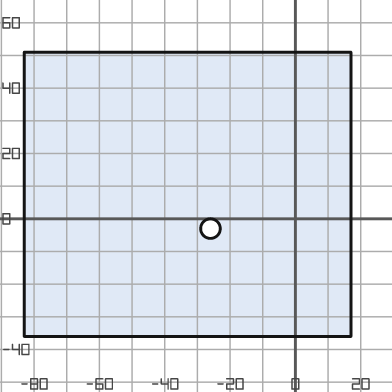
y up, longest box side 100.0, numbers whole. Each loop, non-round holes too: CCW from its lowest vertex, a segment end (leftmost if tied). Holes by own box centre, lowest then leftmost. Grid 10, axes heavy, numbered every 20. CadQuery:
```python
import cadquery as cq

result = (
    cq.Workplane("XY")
    .moveTo(-83.0, -36.0)
    .lineTo(17.0, -36.0)
    .lineTo(17.0, 51.0)
    .lineTo(-83.0, 51.0)
    .close()
    .moveTo(-26.0, -3.0)
    .circle(3.0)
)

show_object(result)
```